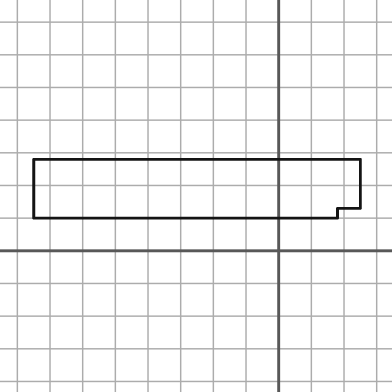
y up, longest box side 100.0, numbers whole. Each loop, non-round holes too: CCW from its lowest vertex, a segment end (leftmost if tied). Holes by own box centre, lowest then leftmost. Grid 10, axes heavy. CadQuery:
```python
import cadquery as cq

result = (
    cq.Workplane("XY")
    .moveTo(-75.0, 10.0)
    .lineTo(18.0, 10.0)
    .lineTo(18.0, 13.0)
    .lineTo(25.0, 13.0)
    .lineTo(25.0, 28.0)
    .lineTo(-75.0, 28.0)
    .close()
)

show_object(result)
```